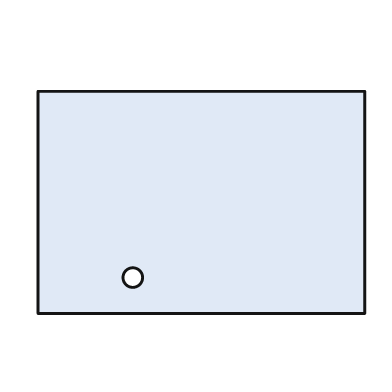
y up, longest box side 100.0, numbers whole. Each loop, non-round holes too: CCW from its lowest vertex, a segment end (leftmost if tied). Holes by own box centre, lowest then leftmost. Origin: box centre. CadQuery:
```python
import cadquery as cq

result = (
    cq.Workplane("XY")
    .moveTo(-50.0, -34.0)
    .lineTo(50.0, -34.0)
    .lineTo(50.0, 34.0)
    .lineTo(-50.0, 34.0)
    .close()
    .moveTo(-21.0, -23.0)
    .circle(3.0)
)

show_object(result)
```